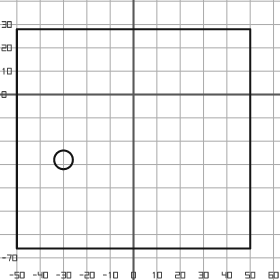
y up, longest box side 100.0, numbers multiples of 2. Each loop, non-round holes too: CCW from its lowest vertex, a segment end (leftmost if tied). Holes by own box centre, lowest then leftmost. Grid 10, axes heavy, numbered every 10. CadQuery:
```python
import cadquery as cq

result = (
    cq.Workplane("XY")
    .moveTo(-50.0, -66.0)
    .lineTo(50.0, -66.0)
    .lineTo(50.0, 28.0)
    .lineTo(-50.0, 28.0)
    .close()
    .moveTo(-30.0, -28.0)
    .circle(4.0)
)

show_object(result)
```